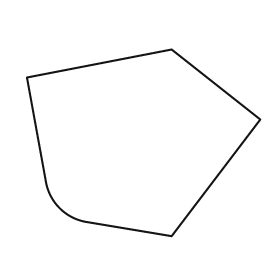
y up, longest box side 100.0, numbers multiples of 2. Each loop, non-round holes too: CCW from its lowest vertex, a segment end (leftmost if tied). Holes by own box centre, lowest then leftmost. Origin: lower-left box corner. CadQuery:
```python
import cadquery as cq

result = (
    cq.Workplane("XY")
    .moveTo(62.0, 0.0)
    .lineTo(100.0, 50.0)
    .lineTo(62.0, 80.0)
    .lineTo(0.0, 68.0)
    .lineTo(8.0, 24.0)
    .threePointArc((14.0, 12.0), (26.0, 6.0))
    .close()
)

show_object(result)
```